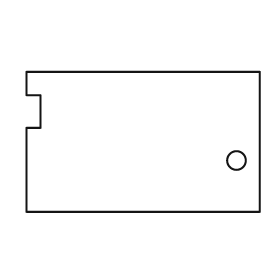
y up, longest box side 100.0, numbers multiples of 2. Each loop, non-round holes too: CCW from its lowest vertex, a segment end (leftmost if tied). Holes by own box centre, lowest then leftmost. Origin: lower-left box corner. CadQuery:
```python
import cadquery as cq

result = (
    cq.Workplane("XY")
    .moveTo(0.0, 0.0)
    .lineTo(100.0, 0.0)
    .lineTo(100.0, 60.0)
    .lineTo(0.0, 60.0)
    .lineTo(0.0, 50.0)
    .lineTo(6.0, 50.0)
    .lineTo(6.0, 36.0)
    .lineTo(0.0, 36.0)
    .close()
    .moveTo(90.0, 22.0)
    .circle(4.0)
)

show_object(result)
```